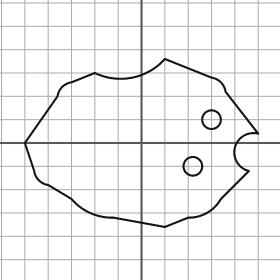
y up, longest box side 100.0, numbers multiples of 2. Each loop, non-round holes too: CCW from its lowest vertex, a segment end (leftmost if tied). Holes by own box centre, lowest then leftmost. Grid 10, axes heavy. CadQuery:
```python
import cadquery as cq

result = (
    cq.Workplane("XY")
    .moveTo(10.0, -36.0)
    .lineTo(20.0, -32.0)
    .threePointArc((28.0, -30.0), (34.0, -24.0))
    .lineTo(46.0, -12.0)
    .threePointArc((40.0, -2.0), (50.0, 4.0))
    .lineTo(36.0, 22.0)
    .threePointArc((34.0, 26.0), (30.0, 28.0))
    .lineTo(10.0, 36.0)
    .threePointArc((-4.0, 28.0), (-20.0, 30.0))
    .lineTo(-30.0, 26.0)
    .threePointArc((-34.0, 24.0), (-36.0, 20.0))
    .lineTo(-50.0, 0.0)
    .lineTo(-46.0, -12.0)
    .threePointArc((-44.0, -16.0), (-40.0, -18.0))
    .lineTo(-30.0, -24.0)
    .threePointArc((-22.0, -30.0), (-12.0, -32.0))
    .close()
    .moveTo(22.0, -10.0)
    .circle(4.0)
    .moveTo(30.0, 10.0)
    .circle(4.0)
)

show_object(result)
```